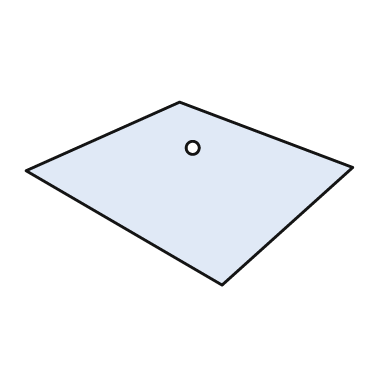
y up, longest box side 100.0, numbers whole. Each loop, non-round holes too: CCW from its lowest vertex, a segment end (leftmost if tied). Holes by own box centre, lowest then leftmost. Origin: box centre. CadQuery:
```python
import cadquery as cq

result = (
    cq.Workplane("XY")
    .moveTo(10.0, -28.0)
    .lineTo(50.0, 8.0)
    .lineTo(-3.0, 28.0)
    .lineTo(-50.0, 7.0)
    .close()
    .moveTo(1.0, 14.0)
    .circle(2.0)
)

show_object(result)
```